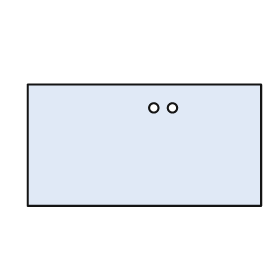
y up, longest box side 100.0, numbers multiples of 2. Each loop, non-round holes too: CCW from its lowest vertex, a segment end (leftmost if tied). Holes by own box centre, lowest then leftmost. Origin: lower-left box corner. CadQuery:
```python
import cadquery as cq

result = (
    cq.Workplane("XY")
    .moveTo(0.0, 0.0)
    .lineTo(100.0, 0.0)
    .lineTo(100.0, 52.0)
    .lineTo(0.0, 52.0)
    .close()
    .moveTo(54.0, 42.0)
    .circle(2.0)
    .moveTo(62.0, 42.0)
    .circle(2.0)
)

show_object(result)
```